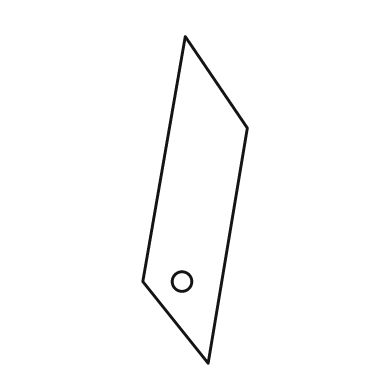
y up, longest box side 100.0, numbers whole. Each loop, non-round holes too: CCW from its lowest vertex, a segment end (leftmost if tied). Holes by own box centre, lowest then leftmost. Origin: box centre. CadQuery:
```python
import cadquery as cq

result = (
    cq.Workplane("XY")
    .moveTo(4.0, -50.0)
    .lineTo(16.0, 22.0)
    .lineTo(-3.0, 50.0)
    .lineTo(-16.0, -25.0)
    .close()
    .moveTo(-4.0, -25.0)
    .circle(3.0)
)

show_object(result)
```